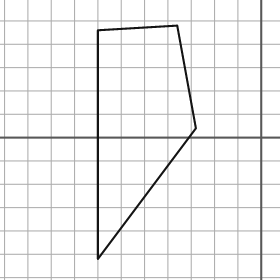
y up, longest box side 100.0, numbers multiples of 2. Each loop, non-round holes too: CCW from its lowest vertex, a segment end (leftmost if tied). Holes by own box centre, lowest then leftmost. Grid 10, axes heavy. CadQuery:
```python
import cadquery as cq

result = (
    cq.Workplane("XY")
    .moveTo(-70.0, -52.0)
    .lineTo(-28.0, 4.0)
    .lineTo(-36.0, 48.0)
    .lineTo(-70.0, 46.0)
    .close()
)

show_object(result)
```